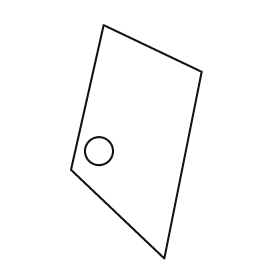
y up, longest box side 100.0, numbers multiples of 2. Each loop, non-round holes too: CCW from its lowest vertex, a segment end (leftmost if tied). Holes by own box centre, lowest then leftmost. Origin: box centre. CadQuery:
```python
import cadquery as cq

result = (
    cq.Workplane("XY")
    .moveTo(12.0, -50.0)
    .lineTo(28.0, 30.0)
    .lineTo(-14.0, 50.0)
    .lineTo(-28.0, -12.0)
    .close()
    .moveTo(-16.0, -4.0)
    .circle(6.0)
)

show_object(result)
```